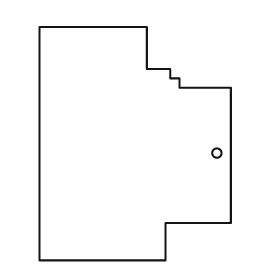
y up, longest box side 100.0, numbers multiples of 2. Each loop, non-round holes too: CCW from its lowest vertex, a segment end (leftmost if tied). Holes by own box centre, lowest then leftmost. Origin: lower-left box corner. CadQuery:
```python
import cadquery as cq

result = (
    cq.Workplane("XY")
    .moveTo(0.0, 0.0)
    .lineTo(54.0, 0.0)
    .lineTo(54.0, 16.0)
    .lineTo(82.0, 16.0)
    .lineTo(82.0, 74.0)
    .lineTo(60.0, 74.0)
    .lineTo(60.0, 78.0)
    .lineTo(56.0, 78.0)
    .lineTo(56.0, 82.0)
    .lineTo(46.0, 82.0)
    .lineTo(46.0, 100.0)
    .lineTo(0.0, 100.0)
    .close()
    .moveTo(76.0, 46.0)
    .circle(2.0)
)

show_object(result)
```